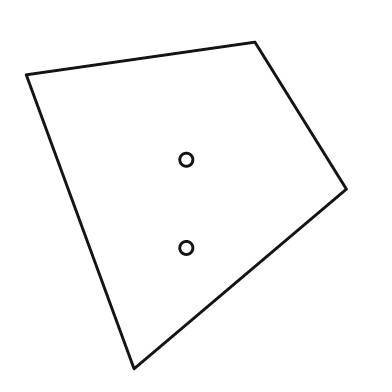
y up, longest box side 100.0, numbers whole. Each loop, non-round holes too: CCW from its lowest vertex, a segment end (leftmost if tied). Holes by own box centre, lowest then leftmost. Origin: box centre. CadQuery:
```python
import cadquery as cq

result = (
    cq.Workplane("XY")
    .moveTo(-16.0, -50.0)
    .lineTo(49.0, 5.0)
    .lineTo(21.0, 50.0)
    .lineTo(-49.0, 40.0)
    .close()
    .moveTo(0.0, -13.0)
    .circle(2.0)
    .moveTo(0.0, 14.0)
    .circle(2.0)
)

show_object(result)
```